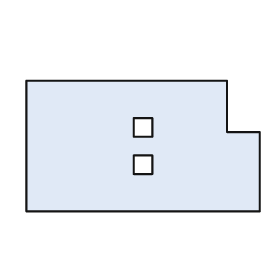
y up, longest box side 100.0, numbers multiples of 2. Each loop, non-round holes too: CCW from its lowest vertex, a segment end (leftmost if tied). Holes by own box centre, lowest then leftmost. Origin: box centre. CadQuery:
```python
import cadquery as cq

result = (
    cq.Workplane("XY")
    .moveTo(-50.0, -28.0)
    .lineTo(50.0, -28.0)
    .lineTo(50.0, 6.0)
    .lineTo(36.0, 6.0)
    .lineTo(36.0, 28.0)
    .lineTo(-50.0, 28.0)
    .close()
    .moveTo(-4.0, -12.0)
    .lineTo(4.0, -12.0)
    .lineTo(4.0, -4.0)
    .lineTo(-4.0, -4.0)
    .close()
    .moveTo(-4.0, 4.0)
    .lineTo(4.0, 4.0)
    .lineTo(4.0, 12.0)
    .lineTo(-4.0, 12.0)
    .close()
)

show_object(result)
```